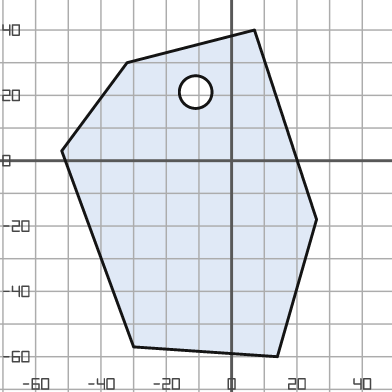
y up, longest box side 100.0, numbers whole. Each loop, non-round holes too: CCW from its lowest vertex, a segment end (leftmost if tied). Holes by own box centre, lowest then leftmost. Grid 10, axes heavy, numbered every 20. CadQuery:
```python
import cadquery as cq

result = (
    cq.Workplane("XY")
    .moveTo(14.0, -60.0)
    .lineTo(26.0, -18.0)
    .lineTo(7.0, 40.0)
    .lineTo(-32.0, 30.0)
    .lineTo(-52.0, 3.0)
    .lineTo(-30.0, -57.0)
    .close()
    .moveTo(-11.0, 21.0)
    .circle(5.0)
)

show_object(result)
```